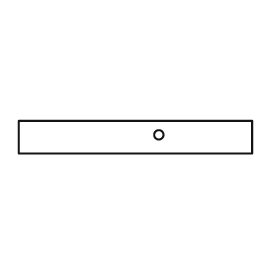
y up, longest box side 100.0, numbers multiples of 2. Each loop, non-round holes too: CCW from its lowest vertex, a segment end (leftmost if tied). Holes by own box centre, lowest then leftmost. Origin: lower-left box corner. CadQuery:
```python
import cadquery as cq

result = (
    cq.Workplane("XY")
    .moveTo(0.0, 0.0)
    .lineTo(100.0, 0.0)
    .lineTo(100.0, 14.0)
    .lineTo(0.0, 14.0)
    .close()
    .moveTo(60.0, 8.0)
    .circle(2.0)
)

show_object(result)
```